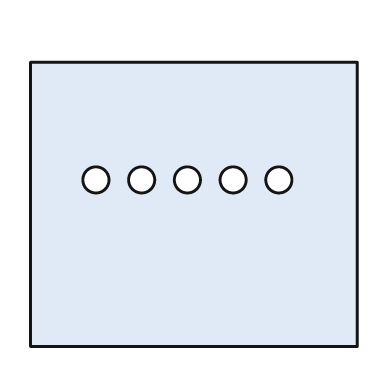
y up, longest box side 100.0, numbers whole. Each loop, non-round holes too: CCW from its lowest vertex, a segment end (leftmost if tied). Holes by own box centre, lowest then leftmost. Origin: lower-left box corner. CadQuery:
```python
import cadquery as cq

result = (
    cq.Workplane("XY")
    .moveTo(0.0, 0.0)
    .lineTo(100.0, 0.0)
    .lineTo(100.0, 87.0)
    .lineTo(0.0, 87.0)
    .close()
    .moveTo(20.0, 51.0)
    .circle(4.0)
    .moveTo(34.0, 51.0)
    .circle(4.0)
    .moveTo(48.0, 51.0)
    .circle(4.0)
    .moveTo(62.0, 51.0)
    .circle(4.0)
    .moveTo(76.0, 51.0)
    .circle(4.0)
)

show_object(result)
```